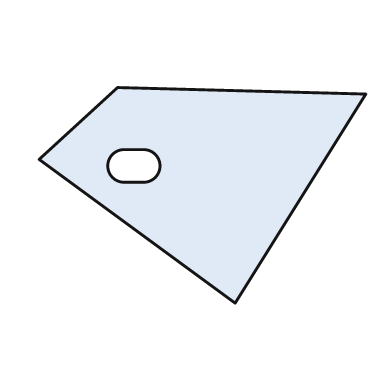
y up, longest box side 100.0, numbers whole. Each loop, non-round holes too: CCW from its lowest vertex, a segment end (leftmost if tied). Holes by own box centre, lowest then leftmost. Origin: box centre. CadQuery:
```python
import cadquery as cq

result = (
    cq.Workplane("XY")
    .moveTo(10.0, -33.0)
    .lineTo(50.0, 31.0)
    .lineTo(-26.0, 33.0)
    .lineTo(-50.0, 11.0)
    .close()
    .moveTo(-24.0, 4.0)
    .lineTo(-18.0, 4.0)
    .threePointArc((-13.0, 9.0), (-18.0, 14.0))
    .lineTo(-24.0, 14.0)
    .threePointArc((-29.0, 9.0), (-24.0, 4.0))
    .close()
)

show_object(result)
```